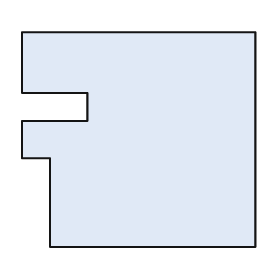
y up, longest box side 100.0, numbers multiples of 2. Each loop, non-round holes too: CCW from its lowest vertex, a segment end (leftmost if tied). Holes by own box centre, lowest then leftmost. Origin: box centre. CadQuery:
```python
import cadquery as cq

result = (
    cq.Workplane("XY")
    .moveTo(-38.0, -46.0)
    .lineTo(50.0, -46.0)
    .lineTo(50.0, 46.0)
    .lineTo(-50.0, 46.0)
    .lineTo(-50.0, 20.0)
    .lineTo(-22.0, 20.0)
    .lineTo(-22.0, 8.0)
    .lineTo(-50.0, 8.0)
    .lineTo(-50.0, -8.0)
    .lineTo(-38.0, -8.0)
    .close()
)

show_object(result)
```